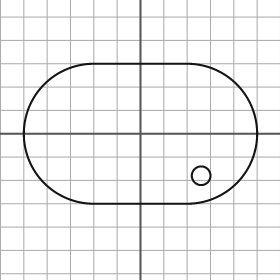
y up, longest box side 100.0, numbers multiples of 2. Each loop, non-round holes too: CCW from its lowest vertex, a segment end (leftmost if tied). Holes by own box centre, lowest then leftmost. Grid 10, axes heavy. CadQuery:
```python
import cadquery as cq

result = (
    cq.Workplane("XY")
    .moveTo(-20.0, -30.0)
    .lineTo(20.0, -30.0)
    .threePointArc((50.0, 0.0), (20.0, 30.0))
    .lineTo(-20.0, 30.0)
    .threePointArc((-50.0, 0.0), (-20.0, -30.0))
    .close()
    .moveTo(26.0, -18.0)
    .circle(4.0)
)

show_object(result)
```